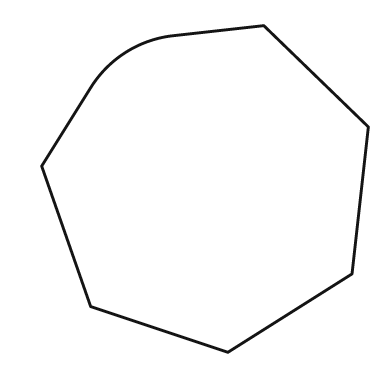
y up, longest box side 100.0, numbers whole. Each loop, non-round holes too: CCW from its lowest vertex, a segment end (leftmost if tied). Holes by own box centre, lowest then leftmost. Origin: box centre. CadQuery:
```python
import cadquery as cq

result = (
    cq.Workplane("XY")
    .moveTo(7.0, -50.0)
    .lineTo(45.0, -26.0)
    .lineTo(50.0, 19.0)
    .lineTo(18.0, 50.0)
    .lineTo(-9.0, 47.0)
    .threePointArc((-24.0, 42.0), (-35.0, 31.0))
    .lineTo(-50.0, 7.0)
    .lineTo(-35.0, -36.0)
    .close()
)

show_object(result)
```